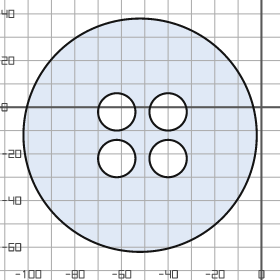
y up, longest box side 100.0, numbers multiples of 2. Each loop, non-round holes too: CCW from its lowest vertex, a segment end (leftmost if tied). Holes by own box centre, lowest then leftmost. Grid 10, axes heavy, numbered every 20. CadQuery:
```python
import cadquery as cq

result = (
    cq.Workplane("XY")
    .moveTo(-52.0, -12.0)
    .circle(50.0)
    .moveTo(-62.0, -22.0)
    .circle(8.0)
    .moveTo(-40.0, -22.0)
    .circle(8.0)
    .moveTo(-62.0, -2.0)
    .circle(8.0)
    .moveTo(-40.0, -2.0)
    .circle(8.0)
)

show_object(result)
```